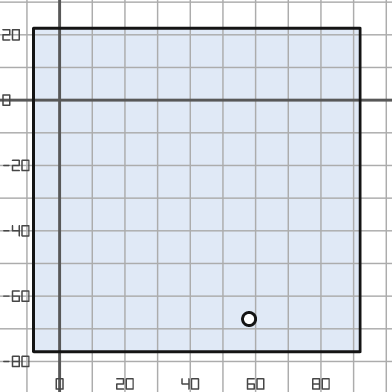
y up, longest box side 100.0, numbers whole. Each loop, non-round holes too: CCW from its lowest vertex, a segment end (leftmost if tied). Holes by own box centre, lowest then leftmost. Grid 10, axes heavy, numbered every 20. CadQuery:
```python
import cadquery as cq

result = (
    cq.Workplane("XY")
    .moveTo(-8.0, -77.0)
    .lineTo(92.0, -77.0)
    .lineTo(92.0, 22.0)
    .lineTo(-8.0, 22.0)
    .close()
    .moveTo(58.0, -67.0)
    .circle(2.0)
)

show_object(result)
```